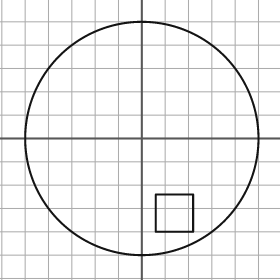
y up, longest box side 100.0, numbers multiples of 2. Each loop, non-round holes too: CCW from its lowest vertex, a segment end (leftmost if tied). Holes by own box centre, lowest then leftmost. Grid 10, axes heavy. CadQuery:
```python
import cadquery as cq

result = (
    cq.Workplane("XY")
    .moveTo(0.0, 0.0)
    .circle(50.0)
    .moveTo(6.0, -40.0)
    .lineTo(22.0, -40.0)
    .lineTo(22.0, -24.0)
    .lineTo(6.0, -24.0)
    .close()
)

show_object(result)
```